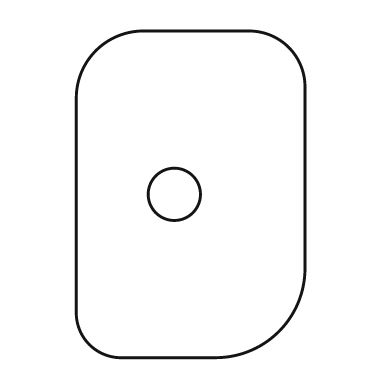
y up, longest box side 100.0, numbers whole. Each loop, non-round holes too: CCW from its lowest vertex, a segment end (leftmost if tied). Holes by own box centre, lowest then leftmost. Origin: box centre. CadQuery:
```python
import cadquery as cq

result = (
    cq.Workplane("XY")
    .moveTo(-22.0, -50.0)
    .lineTo(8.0, -50.0)
    .threePointArc((27.0, -42.0), (35.0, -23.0))
    .lineTo(35.0, 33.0)
    .threePointArc((30.0, 45.0), (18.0, 50.0))
    .lineTo(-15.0, 50.0)
    .threePointArc((-29.0, 44.0), (-35.0, 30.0))
    .lineTo(-35.0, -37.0)
    .threePointArc((-31.0, -46.0), (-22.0, -50.0))
    .close()
    .moveTo(-5.0, 0.0)
    .circle(8.0)
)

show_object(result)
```